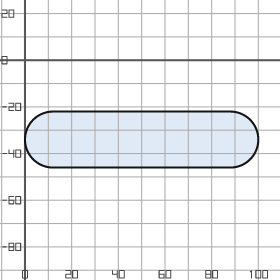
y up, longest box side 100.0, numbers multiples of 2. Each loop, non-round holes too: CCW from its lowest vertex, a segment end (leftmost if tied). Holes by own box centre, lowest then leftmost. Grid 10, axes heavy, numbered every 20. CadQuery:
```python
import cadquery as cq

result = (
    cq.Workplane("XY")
    .moveTo(12.0, -46.0)
    .lineTo(88.0, -46.0)
    .threePointArc((100.0, -34.0), (88.0, -22.0))
    .lineTo(12.0, -22.0)
    .threePointArc((0.0, -34.0), (12.0, -46.0))
    .close()
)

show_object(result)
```